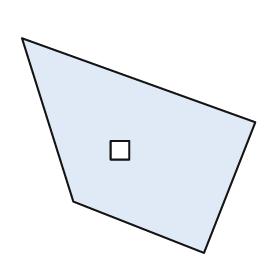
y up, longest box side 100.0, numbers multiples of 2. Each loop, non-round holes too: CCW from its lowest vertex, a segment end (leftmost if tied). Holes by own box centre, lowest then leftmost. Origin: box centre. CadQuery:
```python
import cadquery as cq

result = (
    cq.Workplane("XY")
    .moveTo(28.0, -46.0)
    .lineTo(50.0, 10.0)
    .lineTo(-50.0, 46.0)
    .lineTo(-28.0, -24.0)
    .close()
    .moveTo(-12.0, -6.0)
    .lineTo(-4.0, -6.0)
    .lineTo(-4.0, 2.0)
    .lineTo(-12.0, 2.0)
    .close()
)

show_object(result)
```